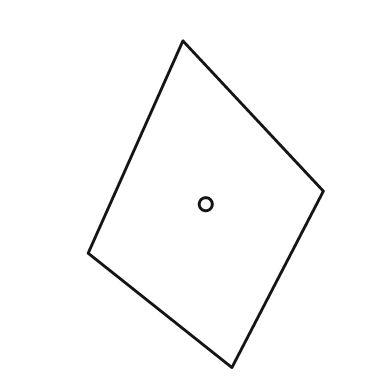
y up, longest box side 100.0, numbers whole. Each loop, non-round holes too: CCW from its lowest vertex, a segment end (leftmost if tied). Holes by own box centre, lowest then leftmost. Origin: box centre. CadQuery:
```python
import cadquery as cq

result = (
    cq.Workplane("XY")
    .moveTo(8.0, -50.0)
    .lineTo(36.0, 4.0)
    .lineTo(-7.0, 50.0)
    .lineTo(-36.0, -15.0)
    .close()
    .moveTo(0.0, 0.0)
    .circle(2.0)
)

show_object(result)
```